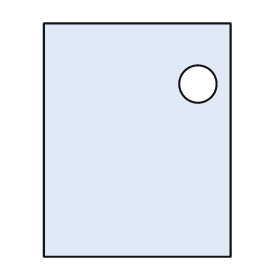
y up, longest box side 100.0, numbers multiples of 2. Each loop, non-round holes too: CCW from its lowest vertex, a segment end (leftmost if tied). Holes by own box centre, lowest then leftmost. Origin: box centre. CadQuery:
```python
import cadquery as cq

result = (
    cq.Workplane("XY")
    .moveTo(-40.0, -50.0)
    .lineTo(40.0, -50.0)
    .lineTo(40.0, 50.0)
    .lineTo(-40.0, 50.0)
    .close()
    .moveTo(26.0, 24.0)
    .circle(8.0)
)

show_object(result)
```